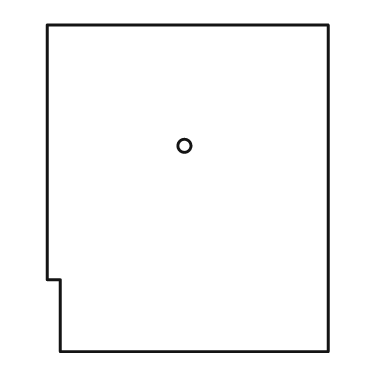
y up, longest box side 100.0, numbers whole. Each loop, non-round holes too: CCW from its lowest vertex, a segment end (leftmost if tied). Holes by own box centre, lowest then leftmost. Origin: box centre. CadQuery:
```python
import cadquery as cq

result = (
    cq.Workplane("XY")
    .moveTo(-39.0, -50.0)
    .lineTo(43.0, -50.0)
    .lineTo(43.0, 50.0)
    .lineTo(-43.0, 50.0)
    .lineTo(-43.0, -28.0)
    .lineTo(-39.0, -28.0)
    .close()
    .moveTo(-1.0, 13.0)
    .circle(2.0)
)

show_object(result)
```